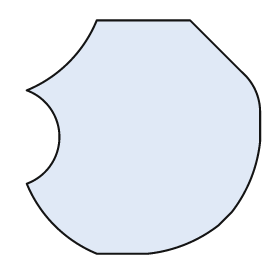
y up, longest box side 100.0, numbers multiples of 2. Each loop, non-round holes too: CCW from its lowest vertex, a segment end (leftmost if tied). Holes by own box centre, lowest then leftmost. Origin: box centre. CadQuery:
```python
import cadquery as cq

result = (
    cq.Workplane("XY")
    .moveTo(-20.0, -50.0)
    .lineTo(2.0, -50.0)
    .threePointArc((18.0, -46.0), (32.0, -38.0))
    .lineTo(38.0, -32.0)
    .threePointArc((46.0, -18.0), (50.0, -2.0))
    .lineTo(50.0, 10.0)
    .threePointArc((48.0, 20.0), (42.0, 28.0))
    .lineTo(20.0, 50.0)
    .lineTo(-20.0, 50.0)
    .threePointArc((-32.0, 32.0), (-50.0, 20.0))
    .threePointArc((-36.0, 0.0), (-50.0, -20.0))
    .threePointArc((-38.0, -38.0), (-20.0, -50.0))
    .close()
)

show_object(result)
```